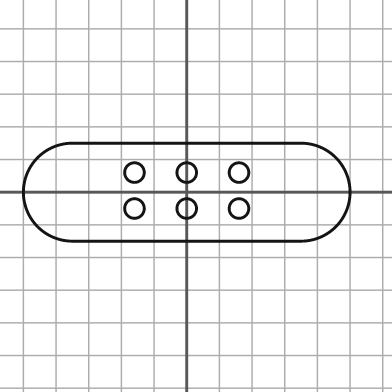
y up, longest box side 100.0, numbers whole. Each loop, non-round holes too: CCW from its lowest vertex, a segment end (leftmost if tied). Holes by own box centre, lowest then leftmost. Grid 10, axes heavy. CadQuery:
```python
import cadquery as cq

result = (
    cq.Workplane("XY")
    .moveTo(-35.0, -15.0)
    .lineTo(35.0, -15.0)
    .threePointArc((50.0, 0.0), (35.0, 15.0))
    .lineTo(-35.0, 15.0)
    .threePointArc((-50.0, 0.0), (-35.0, -15.0))
    .close()
    .moveTo(-16.0, -5.0)
    .circle(3.0)
    .moveTo(0.0, -5.0)
    .circle(3.0)
    .moveTo(16.0, -5.0)
    .circle(3.0)
    .moveTo(-16.0, 6.0)
    .circle(3.0)
    .moveTo(0.0, 6.0)
    .circle(3.0)
    .moveTo(16.0, 6.0)
    .circle(3.0)
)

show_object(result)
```